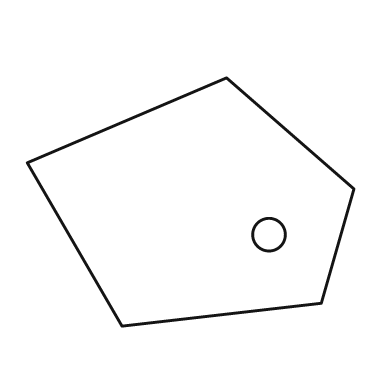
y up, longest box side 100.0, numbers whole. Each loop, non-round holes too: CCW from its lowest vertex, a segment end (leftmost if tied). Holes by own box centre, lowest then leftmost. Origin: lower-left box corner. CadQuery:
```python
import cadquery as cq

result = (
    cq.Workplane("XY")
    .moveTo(29.0, 0.0)
    .lineTo(90.0, 7.0)
    .lineTo(100.0, 42.0)
    .lineTo(61.0, 76.0)
    .lineTo(0.0, 50.0)
    .close()
    .moveTo(74.0, 28.0)
    .circle(5.0)
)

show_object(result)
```